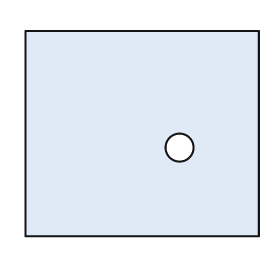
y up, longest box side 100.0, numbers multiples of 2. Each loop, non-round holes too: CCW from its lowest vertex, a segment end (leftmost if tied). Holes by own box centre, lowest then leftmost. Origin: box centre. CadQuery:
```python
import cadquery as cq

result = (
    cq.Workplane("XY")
    .moveTo(-50.0, -44.0)
    .lineTo(50.0, -44.0)
    .lineTo(50.0, 44.0)
    .lineTo(-50.0, 44.0)
    .close()
    .moveTo(16.0, -6.0)
    .circle(6.0)
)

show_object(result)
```